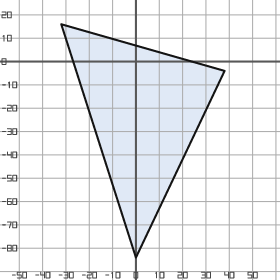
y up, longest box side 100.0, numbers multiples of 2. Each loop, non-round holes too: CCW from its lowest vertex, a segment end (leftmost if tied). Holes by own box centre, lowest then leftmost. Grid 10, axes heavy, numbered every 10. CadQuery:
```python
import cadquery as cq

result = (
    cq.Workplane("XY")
    .moveTo(0.0, -84.0)
    .lineTo(38.0, -4.0)
    .lineTo(-32.0, 16.0)
    .close()
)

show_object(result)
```